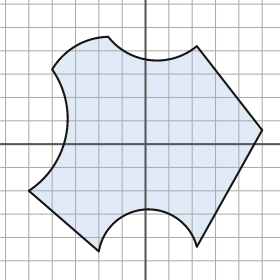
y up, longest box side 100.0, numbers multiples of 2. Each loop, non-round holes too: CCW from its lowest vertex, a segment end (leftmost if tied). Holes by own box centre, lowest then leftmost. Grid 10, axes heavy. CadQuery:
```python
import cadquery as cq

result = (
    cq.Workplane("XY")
    .moveTo(-20.0, -46.0)
    .threePointArc((0.0, -28.0), (22.0, -44.0))
    .lineTo(50.0, 6.0)
    .lineTo(22.0, 42.0)
    .threePointArc((2.0, 36.0), (-16.0, 46.0))
    .threePointArc((-30.0, 42.0), (-40.0, 32.0))
    .threePointArc((-34.0, 4.0), (-50.0, -20.0))
    .close()
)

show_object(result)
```